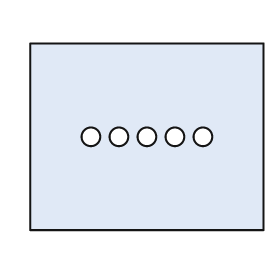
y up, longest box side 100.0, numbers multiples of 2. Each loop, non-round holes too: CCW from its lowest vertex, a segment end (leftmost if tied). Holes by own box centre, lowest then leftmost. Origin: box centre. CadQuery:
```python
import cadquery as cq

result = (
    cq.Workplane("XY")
    .moveTo(-50.0, -40.0)
    .lineTo(50.0, -40.0)
    .lineTo(50.0, 40.0)
    .lineTo(-50.0, 40.0)
    .close()
    .moveTo(-24.0, 0.0)
    .circle(4.0)
    .moveTo(-12.0, 0.0)
    .circle(4.0)
    .moveTo(0.0, 0.0)
    .circle(4.0)
    .moveTo(12.0, 0.0)
    .circle(4.0)
    .moveTo(24.0, 0.0)
    .circle(4.0)
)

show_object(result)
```